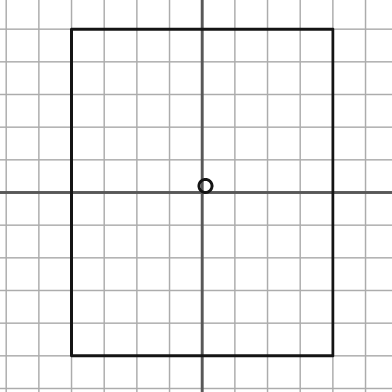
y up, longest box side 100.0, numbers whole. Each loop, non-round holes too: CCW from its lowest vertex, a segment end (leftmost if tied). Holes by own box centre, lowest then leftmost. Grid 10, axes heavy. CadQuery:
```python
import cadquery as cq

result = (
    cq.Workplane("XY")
    .moveTo(-40.0, -50.0)
    .lineTo(40.0, -50.0)
    .lineTo(40.0, 50.0)
    .lineTo(-40.0, 50.0)
    .close()
    .moveTo(1.0, 2.0)
    .circle(2.0)
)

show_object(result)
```